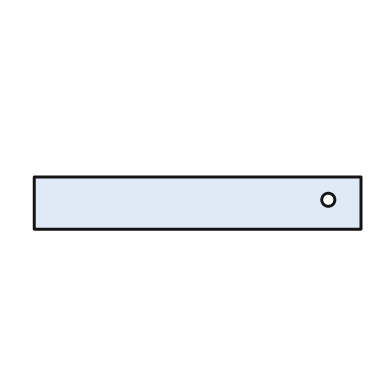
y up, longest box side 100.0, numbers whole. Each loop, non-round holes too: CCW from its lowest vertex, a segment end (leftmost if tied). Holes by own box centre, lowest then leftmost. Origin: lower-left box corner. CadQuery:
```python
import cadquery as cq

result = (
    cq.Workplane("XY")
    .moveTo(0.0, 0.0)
    .lineTo(100.0, 0.0)
    .lineTo(100.0, 16.0)
    .lineTo(0.0, 16.0)
    .close()
    .moveTo(90.0, 9.0)
    .circle(2.0)
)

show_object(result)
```